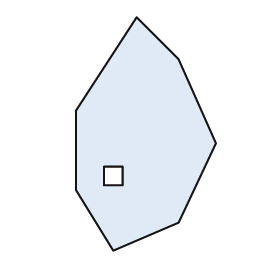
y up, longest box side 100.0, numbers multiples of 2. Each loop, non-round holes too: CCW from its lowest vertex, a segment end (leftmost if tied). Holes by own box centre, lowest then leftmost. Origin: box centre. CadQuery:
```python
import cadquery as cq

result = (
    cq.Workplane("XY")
    .moveTo(-14.0, -50.0)
    .lineTo(14.0, -38.0)
    .lineTo(30.0, -4.0)
    .lineTo(14.0, 32.0)
    .lineTo(-4.0, 50.0)
    .lineTo(-30.0, 10.0)
    .lineTo(-30.0, -24.0)
    .close()
    .moveTo(-18.0, -22.0)
    .lineTo(-10.0, -22.0)
    .lineTo(-10.0, -14.0)
    .lineTo(-18.0, -14.0)
    .close()
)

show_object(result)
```